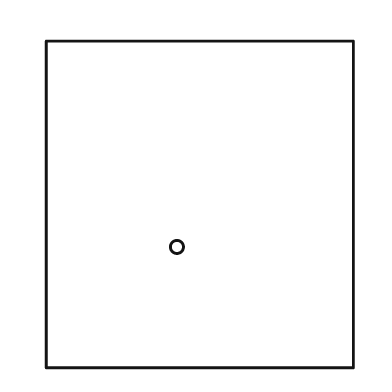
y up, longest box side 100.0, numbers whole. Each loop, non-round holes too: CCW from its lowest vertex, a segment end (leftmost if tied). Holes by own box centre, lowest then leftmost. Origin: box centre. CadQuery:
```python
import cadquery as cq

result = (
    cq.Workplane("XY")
    .moveTo(-47.0, -50.0)
    .lineTo(47.0, -50.0)
    .lineTo(47.0, 50.0)
    .lineTo(-47.0, 50.0)
    .close()
    .moveTo(-7.0, -13.0)
    .circle(2.0)
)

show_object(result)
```